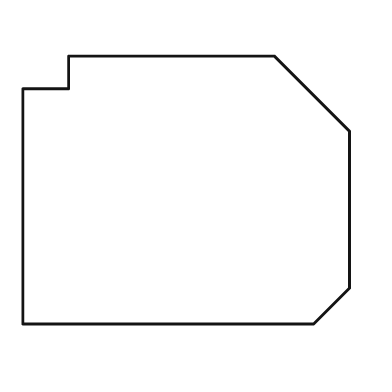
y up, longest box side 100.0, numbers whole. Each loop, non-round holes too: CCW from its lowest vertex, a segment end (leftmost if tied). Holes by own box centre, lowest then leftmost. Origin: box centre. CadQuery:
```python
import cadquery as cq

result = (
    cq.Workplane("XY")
    .moveTo(-50.0, -41.0)
    .lineTo(39.0, -41.0)
    .lineTo(50.0, -30.0)
    .lineTo(50.0, 18.0)
    .lineTo(27.0, 41.0)
    .lineTo(-36.0, 41.0)
    .lineTo(-36.0, 31.0)
    .lineTo(-50.0, 31.0)
    .close()
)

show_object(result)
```